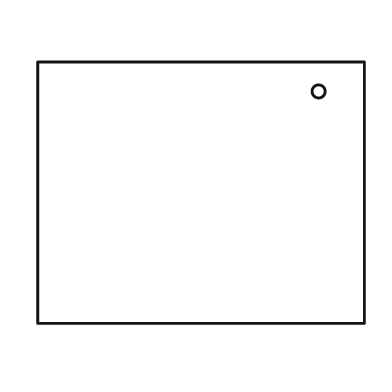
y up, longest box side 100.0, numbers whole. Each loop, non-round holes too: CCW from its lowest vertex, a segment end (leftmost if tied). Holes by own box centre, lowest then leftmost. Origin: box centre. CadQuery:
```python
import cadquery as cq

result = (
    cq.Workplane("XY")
    .moveTo(-50.0, -40.0)
    .lineTo(50.0, -40.0)
    .lineTo(50.0, 40.0)
    .lineTo(-50.0, 40.0)
    .close()
    .moveTo(36.0, 31.0)
    .circle(2.0)
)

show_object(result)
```